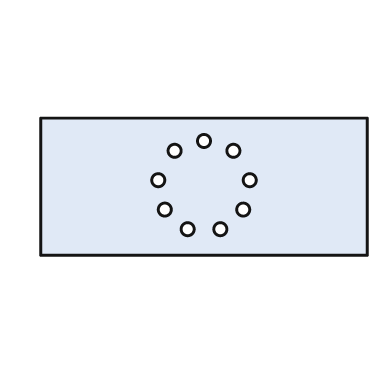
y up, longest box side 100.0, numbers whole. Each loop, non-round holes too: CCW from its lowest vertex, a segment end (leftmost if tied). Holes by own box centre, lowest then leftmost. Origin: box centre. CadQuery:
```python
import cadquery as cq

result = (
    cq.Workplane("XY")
    .moveTo(-50.0, -21.0)
    .lineTo(50.0, -21.0)
    .lineTo(50.0, 21.0)
    .lineTo(-50.0, 21.0)
    .close()
    .moveTo(-5.0, -13.0)
    .circle(2.0)
    .moveTo(5.0, -13.0)
    .circle(2.0)
    .moveTo(-12.0, -7.0)
    .circle(2.0)
    .moveTo(12.0, -7.0)
    .circle(2.0)
    .moveTo(-14.0, 2.0)
    .circle(2.0)
    .moveTo(14.0, 2.0)
    .circle(2.0)
    .moveTo(-9.0, 11.0)
    .circle(2.0)
    .moveTo(9.0, 11.0)
    .circle(2.0)
    .moveTo(0.0, 14.0)
    .circle(2.0)
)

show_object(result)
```